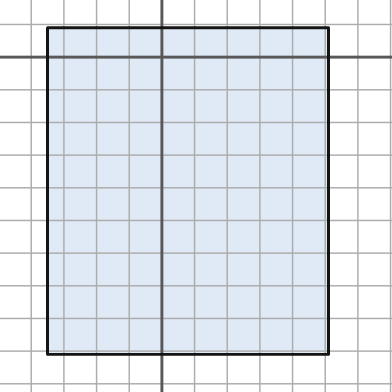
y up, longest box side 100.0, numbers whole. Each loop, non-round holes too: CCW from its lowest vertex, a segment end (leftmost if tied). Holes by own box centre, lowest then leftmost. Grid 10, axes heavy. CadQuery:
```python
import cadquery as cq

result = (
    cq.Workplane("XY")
    .moveTo(-35.0, -91.0)
    .lineTo(51.0, -91.0)
    .lineTo(51.0, 9.0)
    .lineTo(-35.0, 9.0)
    .close()
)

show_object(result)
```